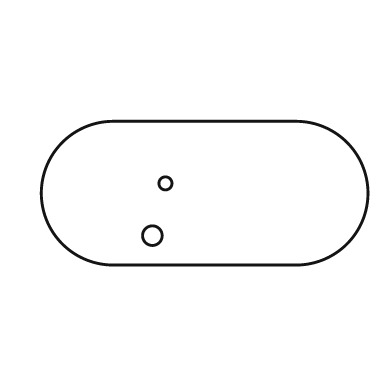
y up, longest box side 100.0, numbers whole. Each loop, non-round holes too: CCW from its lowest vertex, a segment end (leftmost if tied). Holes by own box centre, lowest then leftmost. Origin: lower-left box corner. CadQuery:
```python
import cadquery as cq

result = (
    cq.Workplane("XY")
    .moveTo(22.0, 0.0)
    .lineTo(78.0, 0.0)
    .threePointArc((100.0, 22.0), (78.0, 44.0))
    .lineTo(22.0, 44.0)
    .threePointArc((0.0, 22.0), (22.0, 0.0))
    .close()
    .moveTo(34.0, 9.0)
    .circle(3.0)
    .moveTo(38.0, 25.0)
    .circle(2.0)
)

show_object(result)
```